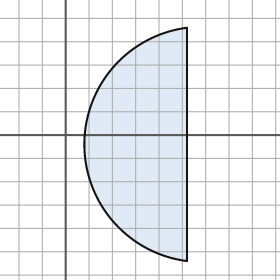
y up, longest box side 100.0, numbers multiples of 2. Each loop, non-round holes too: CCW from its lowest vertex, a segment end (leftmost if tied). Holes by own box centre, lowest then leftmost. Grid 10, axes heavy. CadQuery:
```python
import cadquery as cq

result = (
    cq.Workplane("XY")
    .moveTo(52.0, -54.0)
    .lineTo(52.0, 46.0)
    .threePointArc((8.0, -4.0), (52.0, -54.0))
    .close()
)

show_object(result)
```